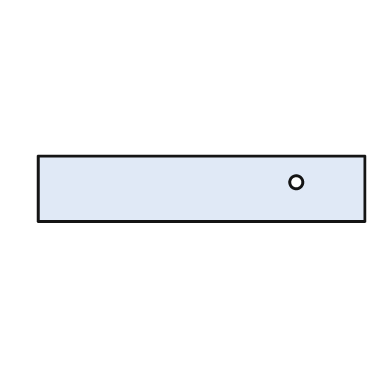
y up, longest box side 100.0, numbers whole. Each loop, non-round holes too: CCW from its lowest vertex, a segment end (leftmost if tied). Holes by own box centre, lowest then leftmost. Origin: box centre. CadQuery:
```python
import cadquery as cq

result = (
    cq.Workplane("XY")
    .moveTo(-50.0, -10.0)
    .lineTo(50.0, -10.0)
    .lineTo(50.0, 10.0)
    .lineTo(-50.0, 10.0)
    .close()
    .moveTo(29.0, 2.0)
    .circle(2.0)
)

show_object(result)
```